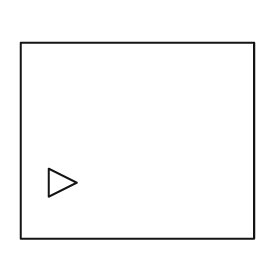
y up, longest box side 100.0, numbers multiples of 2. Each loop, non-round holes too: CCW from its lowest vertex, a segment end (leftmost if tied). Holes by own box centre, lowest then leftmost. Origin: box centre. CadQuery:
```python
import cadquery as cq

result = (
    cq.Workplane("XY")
    .moveTo(-50.0, -42.0)
    .lineTo(50.0, -42.0)
    .lineTo(50.0, 42.0)
    .lineTo(-50.0, 42.0)
    .close()
    .moveTo(-38.0, -24.0)
    .lineTo(-26.0, -18.0)
    .lineTo(-38.0, -12.0)
    .close()
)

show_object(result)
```